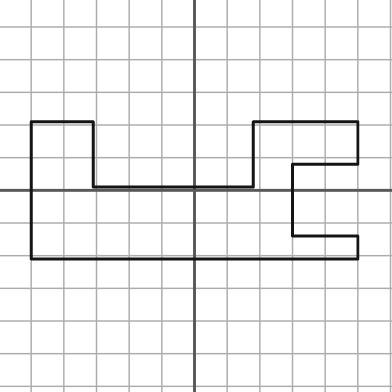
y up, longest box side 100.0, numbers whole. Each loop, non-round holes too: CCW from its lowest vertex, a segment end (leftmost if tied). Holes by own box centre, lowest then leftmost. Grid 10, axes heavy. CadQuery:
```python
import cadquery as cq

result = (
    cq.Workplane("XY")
    .moveTo(-50.0, -21.0)
    .lineTo(50.0, -21.0)
    .lineTo(50.0, -14.0)
    .lineTo(30.0, -14.0)
    .lineTo(30.0, 8.0)
    .lineTo(50.0, 8.0)
    .lineTo(50.0, 21.0)
    .lineTo(18.0, 21.0)
    .lineTo(18.0, 1.0)
    .lineTo(-31.0, 1.0)
    .lineTo(-31.0, 21.0)
    .lineTo(-50.0, 21.0)
    .close()
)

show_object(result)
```